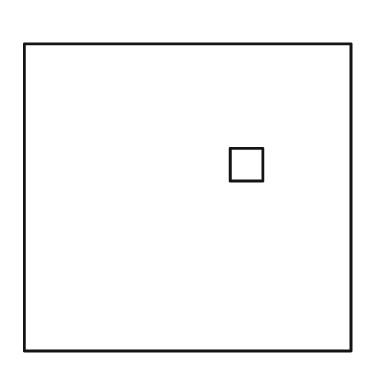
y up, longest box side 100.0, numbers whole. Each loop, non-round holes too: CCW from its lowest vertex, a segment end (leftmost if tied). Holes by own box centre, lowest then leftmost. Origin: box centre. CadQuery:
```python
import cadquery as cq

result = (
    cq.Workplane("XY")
    .moveTo(-50.0, -47.0)
    .lineTo(50.0, -47.0)
    .lineTo(50.0, 47.0)
    .lineTo(-50.0, 47.0)
    .close()
    .moveTo(13.0, 5.0)
    .lineTo(23.0, 5.0)
    .lineTo(23.0, 15.0)
    .lineTo(13.0, 15.0)
    .close()
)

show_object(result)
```